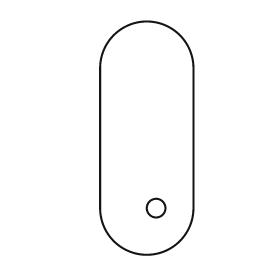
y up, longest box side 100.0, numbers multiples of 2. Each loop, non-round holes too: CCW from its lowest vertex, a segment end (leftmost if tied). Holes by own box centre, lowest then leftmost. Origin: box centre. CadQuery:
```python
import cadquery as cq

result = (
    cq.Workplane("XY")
    .moveTo(-20.0, -30.0)
    .threePointArc((0.0, -50.0), (20.0, -30.0))
    .lineTo(20.0, 30.0)
    .threePointArc((0.0, 50.0), (-20.0, 30.0))
    .close()
    .moveTo(4.0, -30.0)
    .circle(4.0)
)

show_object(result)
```